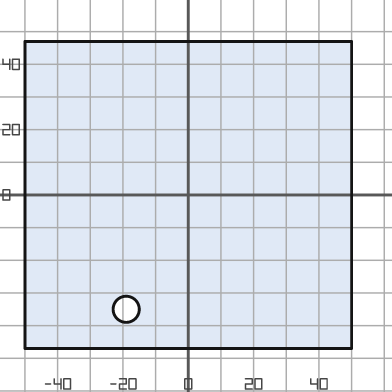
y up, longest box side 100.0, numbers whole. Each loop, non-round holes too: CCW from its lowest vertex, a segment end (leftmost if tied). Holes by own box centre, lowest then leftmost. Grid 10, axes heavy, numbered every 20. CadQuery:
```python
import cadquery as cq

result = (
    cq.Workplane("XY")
    .moveTo(-50.0, -47.0)
    .lineTo(50.0, -47.0)
    .lineTo(50.0, 47.0)
    .lineTo(-50.0, 47.0)
    .close()
    .moveTo(-19.0, -35.0)
    .circle(4.0)
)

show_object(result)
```